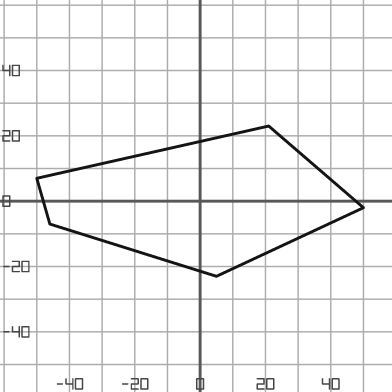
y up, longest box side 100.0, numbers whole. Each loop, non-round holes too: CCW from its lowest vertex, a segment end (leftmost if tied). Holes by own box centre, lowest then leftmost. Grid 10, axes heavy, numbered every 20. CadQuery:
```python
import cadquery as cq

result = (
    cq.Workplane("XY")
    .moveTo(5.0, -23.0)
    .lineTo(50.0, -2.0)
    .lineTo(21.0, 23.0)
    .lineTo(-50.0, 7.0)
    .lineTo(-46.0, -7.0)
    .close()
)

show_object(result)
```